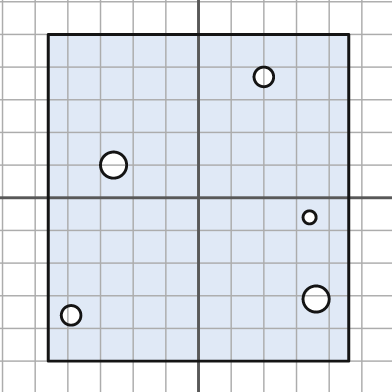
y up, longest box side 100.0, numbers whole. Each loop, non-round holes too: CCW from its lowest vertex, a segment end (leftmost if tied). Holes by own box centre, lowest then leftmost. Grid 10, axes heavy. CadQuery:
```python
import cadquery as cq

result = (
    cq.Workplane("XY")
    .moveTo(-46.0, -50.0)
    .lineTo(46.0, -50.0)
    .lineTo(46.0, 50.0)
    .lineTo(-46.0, 50.0)
    .close()
    .moveTo(-39.0, -36.0)
    .circle(3.0)
    .moveTo(36.0, -31.0)
    .circle(4.0)
    .moveTo(34.0, -6.0)
    .circle(2.0)
    .moveTo(-26.0, 10.0)
    .circle(4.0)
    .moveTo(20.0, 37.0)
    .circle(3.0)
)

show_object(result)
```